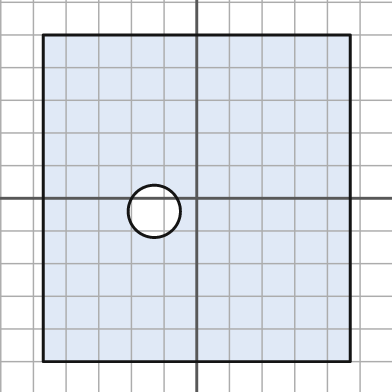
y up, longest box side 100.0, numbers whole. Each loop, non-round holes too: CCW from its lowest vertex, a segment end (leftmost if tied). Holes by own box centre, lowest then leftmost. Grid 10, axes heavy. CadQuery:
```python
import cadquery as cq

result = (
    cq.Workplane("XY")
    .moveTo(-47.0, -50.0)
    .lineTo(47.0, -50.0)
    .lineTo(47.0, 50.0)
    .lineTo(-47.0, 50.0)
    .close()
    .moveTo(-13.0, -4.0)
    .circle(8.0)
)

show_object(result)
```